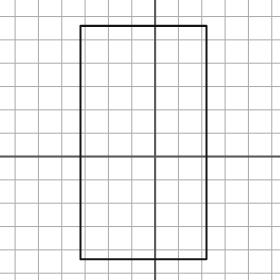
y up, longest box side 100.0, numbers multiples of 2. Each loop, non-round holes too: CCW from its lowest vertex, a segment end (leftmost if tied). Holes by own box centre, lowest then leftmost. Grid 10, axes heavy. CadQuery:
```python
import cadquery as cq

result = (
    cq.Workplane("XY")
    .moveTo(-32.0, -44.0)
    .lineTo(22.0, -44.0)
    .lineTo(22.0, 56.0)
    .lineTo(-32.0, 56.0)
    .close()
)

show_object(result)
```